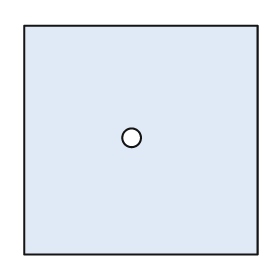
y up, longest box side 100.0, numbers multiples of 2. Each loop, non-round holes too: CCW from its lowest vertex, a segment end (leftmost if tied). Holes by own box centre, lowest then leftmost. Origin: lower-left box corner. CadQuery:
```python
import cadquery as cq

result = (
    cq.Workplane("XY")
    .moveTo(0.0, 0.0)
    .lineTo(100.0, 0.0)
    .lineTo(100.0, 98.0)
    .lineTo(0.0, 98.0)
    .close()
    .moveTo(46.0, 50.0)
    .circle(4.0)
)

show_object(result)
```